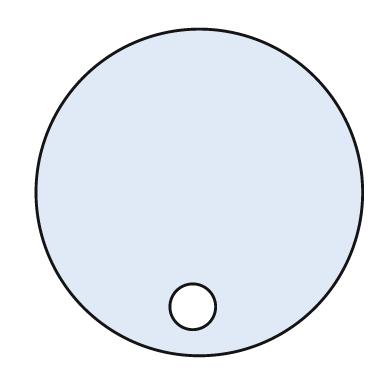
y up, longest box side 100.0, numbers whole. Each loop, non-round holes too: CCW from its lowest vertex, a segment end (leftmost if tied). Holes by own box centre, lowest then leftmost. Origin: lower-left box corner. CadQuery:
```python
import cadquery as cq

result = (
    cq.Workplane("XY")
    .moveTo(50.0, 50.0)
    .circle(50.0)
    .moveTo(48.0, 15.0)
    .circle(7.0)
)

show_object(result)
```